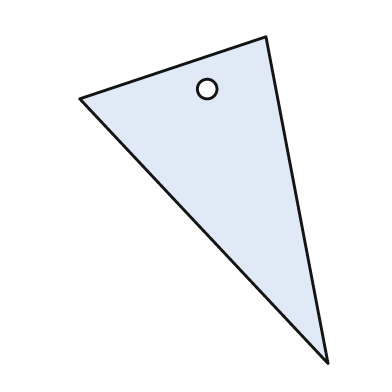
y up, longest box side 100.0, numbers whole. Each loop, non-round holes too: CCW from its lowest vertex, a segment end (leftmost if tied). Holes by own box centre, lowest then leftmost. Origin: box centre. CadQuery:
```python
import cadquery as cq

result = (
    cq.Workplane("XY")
    .moveTo(38.0, -50.0)
    .lineTo(19.0, 50.0)
    .lineTo(-38.0, 31.0)
    .close()
    .moveTo(1.0, 34.0)
    .circle(3.0)
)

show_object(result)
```